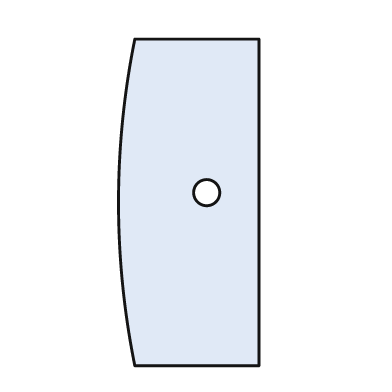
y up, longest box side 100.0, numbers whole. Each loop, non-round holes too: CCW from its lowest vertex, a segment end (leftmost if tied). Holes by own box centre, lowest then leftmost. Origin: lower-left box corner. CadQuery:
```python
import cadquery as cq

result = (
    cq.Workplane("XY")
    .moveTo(5.0, 0.0)
    .lineTo(43.0, 0.0)
    .lineTo(43.0, 100.0)
    .lineTo(5.0, 100.0)
    .threePointArc((0.0, 50.0), (5.0, 0.0))
    .close()
    .moveTo(27.0, 53.0)
    .circle(4.0)
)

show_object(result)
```